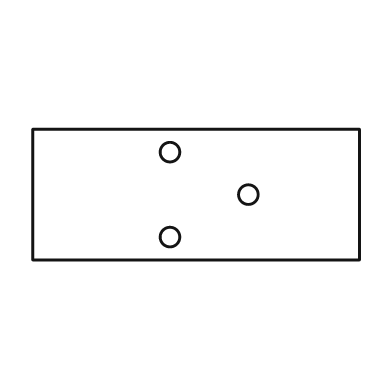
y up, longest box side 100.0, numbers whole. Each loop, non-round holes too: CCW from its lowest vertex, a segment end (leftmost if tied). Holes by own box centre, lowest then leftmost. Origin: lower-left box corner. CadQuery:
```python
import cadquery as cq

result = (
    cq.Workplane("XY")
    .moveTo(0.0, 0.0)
    .lineTo(100.0, 0.0)
    .lineTo(100.0, 40.0)
    .lineTo(0.0, 40.0)
    .close()
    .moveTo(42.0, 7.0)
    .circle(3.0)
    .moveTo(66.0, 20.0)
    .circle(3.0)
    .moveTo(42.0, 33.0)
    .circle(3.0)
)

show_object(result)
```